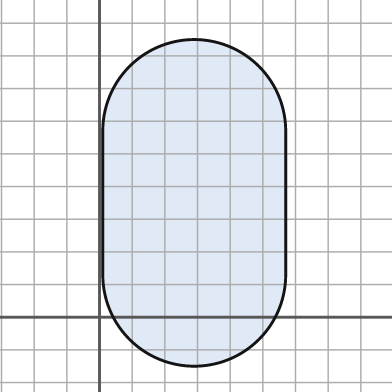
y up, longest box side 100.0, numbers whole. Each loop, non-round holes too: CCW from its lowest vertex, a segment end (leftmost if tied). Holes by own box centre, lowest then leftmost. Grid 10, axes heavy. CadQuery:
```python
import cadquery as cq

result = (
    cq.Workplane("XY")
    .moveTo(1.0, 13.0)
    .threePointArc((29.0, -15.0), (57.0, 13.0))
    .lineTo(57.0, 57.0)
    .threePointArc((29.0, 85.0), (1.0, 57.0))
    .close()
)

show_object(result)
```